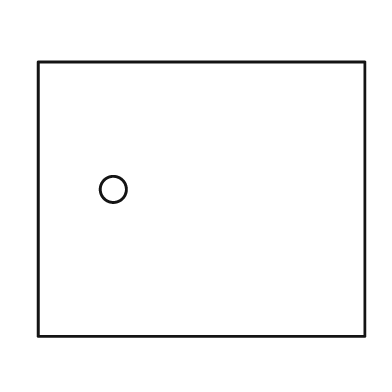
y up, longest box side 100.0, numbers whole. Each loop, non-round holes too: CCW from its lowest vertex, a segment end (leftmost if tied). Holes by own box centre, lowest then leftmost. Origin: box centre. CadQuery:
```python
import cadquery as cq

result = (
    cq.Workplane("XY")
    .moveTo(-50.0, -42.0)
    .lineTo(50.0, -42.0)
    .lineTo(50.0, 42.0)
    .lineTo(-50.0, 42.0)
    .close()
    .moveTo(-27.0, 3.0)
    .circle(4.0)
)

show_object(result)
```